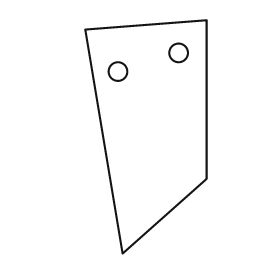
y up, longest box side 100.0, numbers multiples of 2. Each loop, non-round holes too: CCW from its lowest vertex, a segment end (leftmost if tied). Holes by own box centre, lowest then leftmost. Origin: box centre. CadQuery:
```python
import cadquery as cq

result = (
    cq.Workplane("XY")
    .moveTo(-10.0, -50.0)
    .lineTo(26.0, -18.0)
    .lineTo(26.0, 50.0)
    .lineTo(-26.0, 46.0)
    .close()
    .moveTo(-12.0, 28.0)
    .circle(4.0)
    .moveTo(14.0, 36.0)
    .circle(4.0)
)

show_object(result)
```